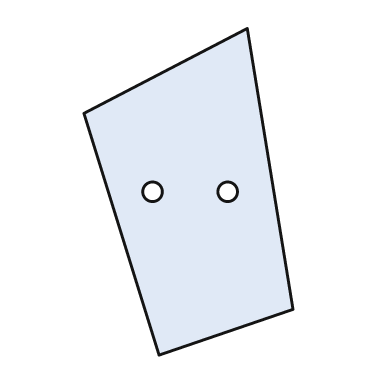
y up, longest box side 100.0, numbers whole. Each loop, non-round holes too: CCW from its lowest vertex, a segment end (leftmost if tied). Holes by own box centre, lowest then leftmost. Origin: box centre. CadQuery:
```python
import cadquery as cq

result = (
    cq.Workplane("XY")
    .moveTo(-9.0, -50.0)
    .lineTo(32.0, -36.0)
    .lineTo(18.0, 50.0)
    .lineTo(-32.0, 24.0)
    .close()
    .moveTo(-11.0, 0.0)
    .circle(3.0)
    .moveTo(12.0, 0.0)
    .circle(3.0)
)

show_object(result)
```